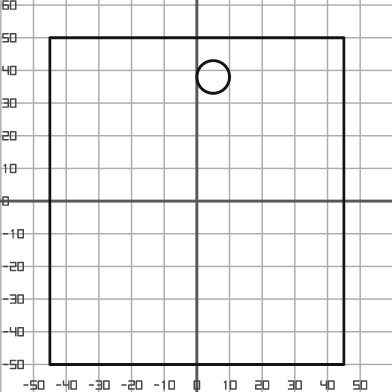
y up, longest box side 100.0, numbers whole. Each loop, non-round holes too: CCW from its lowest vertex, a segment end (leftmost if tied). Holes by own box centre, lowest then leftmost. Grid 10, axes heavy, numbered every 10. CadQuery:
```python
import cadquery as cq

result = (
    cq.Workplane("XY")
    .moveTo(-45.0, -50.0)
    .lineTo(45.0, -50.0)
    .lineTo(45.0, 50.0)
    .lineTo(-45.0, 50.0)
    .close()
    .moveTo(5.0, 38.0)
    .circle(5.0)
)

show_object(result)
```